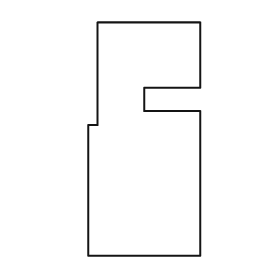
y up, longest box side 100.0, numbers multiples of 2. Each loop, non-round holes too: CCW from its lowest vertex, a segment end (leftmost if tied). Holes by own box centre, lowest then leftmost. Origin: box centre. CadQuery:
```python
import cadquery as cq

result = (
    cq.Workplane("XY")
    .moveTo(-24.0, -50.0)
    .lineTo(24.0, -50.0)
    .lineTo(24.0, 12.0)
    .lineTo(0.0, 12.0)
    .lineTo(0.0, 22.0)
    .lineTo(24.0, 22.0)
    .lineTo(24.0, 50.0)
    .lineTo(-20.0, 50.0)
    .lineTo(-20.0, 6.0)
    .lineTo(-24.0, 6.0)
    .close()
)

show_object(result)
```